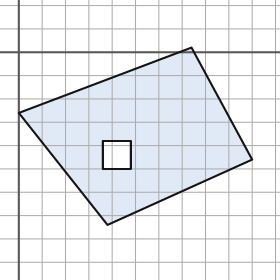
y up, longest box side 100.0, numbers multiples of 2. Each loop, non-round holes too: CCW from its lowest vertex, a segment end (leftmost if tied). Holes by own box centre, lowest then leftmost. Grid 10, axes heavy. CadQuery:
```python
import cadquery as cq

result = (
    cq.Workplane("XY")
    .moveTo(38.0, -74.0)
    .lineTo(100.0, -46.0)
    .lineTo(74.0, 2.0)
    .lineTo(0.0, -26.0)
    .close()
    .moveTo(36.0, -50.0)
    .lineTo(48.0, -50.0)
    .lineTo(48.0, -38.0)
    .lineTo(36.0, -38.0)
    .close()
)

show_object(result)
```